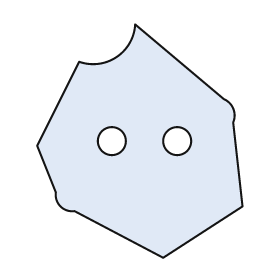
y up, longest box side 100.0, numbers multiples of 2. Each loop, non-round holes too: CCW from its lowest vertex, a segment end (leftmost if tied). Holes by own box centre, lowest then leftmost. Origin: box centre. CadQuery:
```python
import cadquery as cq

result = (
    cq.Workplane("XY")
    .moveTo(10.0, -50.0)
    .lineTo(44.0, -28.0)
    .lineTo(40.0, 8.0)
    .threePointArc((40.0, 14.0), (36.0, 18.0))
    .lineTo(-2.0, 50.0)
    .threePointArc((-10.0, 36.0), (-26.0, 34.0))
    .lineTo(-44.0, -2.0)
    .lineTo(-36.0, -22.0)
    .threePointArc((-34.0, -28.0), (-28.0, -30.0))
    .close()
    .moveTo(-12.0, 0.0)
    .circle(6.0)
    .moveTo(16.0, 0.0)
    .circle(6.0)
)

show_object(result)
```